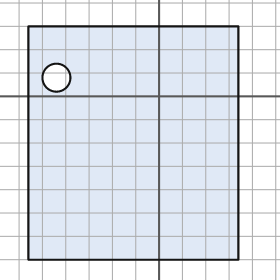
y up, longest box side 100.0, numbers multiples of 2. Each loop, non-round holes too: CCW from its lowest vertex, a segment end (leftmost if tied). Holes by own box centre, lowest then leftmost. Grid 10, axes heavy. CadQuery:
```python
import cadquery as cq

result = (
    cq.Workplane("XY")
    .moveTo(-56.0, -70.0)
    .lineTo(34.0, -70.0)
    .lineTo(34.0, 30.0)
    .lineTo(-56.0, 30.0)
    .close()
    .moveTo(-44.0, 8.0)
    .circle(6.0)
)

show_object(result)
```